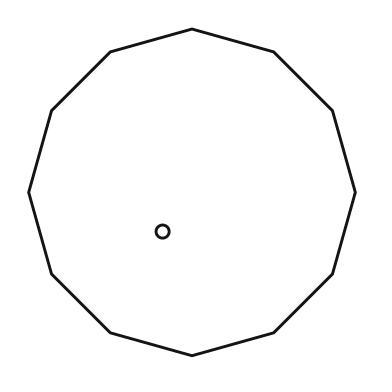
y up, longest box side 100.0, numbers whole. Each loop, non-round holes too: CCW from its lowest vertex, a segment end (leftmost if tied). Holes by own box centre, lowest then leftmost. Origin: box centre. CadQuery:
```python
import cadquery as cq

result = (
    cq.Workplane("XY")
    .moveTo(0.0, -50.0)
    .lineTo(25.0, -43.0)
    .lineTo(43.0, -25.0)
    .lineTo(50.0, 0.0)
    .lineTo(43.0, 25.0)
    .lineTo(25.0, 43.0)
    .lineTo(0.0, 50.0)
    .lineTo(-25.0, 43.0)
    .lineTo(-43.0, 25.0)
    .lineTo(-50.0, 0.0)
    .lineTo(-43.0, -25.0)
    .lineTo(-25.0, -43.0)
    .close()
    .moveTo(-9.0, -12.0)
    .circle(2.0)
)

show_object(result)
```